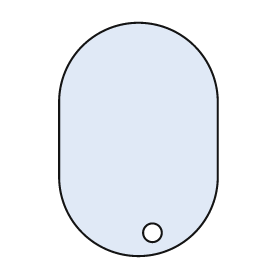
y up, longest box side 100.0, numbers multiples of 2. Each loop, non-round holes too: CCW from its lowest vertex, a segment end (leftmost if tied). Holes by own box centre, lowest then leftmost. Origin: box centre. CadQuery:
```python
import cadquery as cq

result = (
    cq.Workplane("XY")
    .moveTo(-34.0, -16.0)
    .threePointArc((0.0, -50.0), (34.0, -16.0))
    .lineTo(34.0, 16.0)
    .threePointArc((0.0, 50.0), (-34.0, 16.0))
    .close()
    .moveTo(6.0, -40.0)
    .circle(4.0)
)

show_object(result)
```